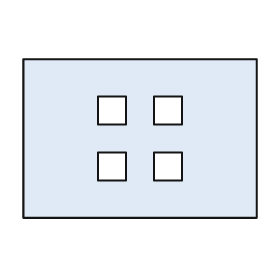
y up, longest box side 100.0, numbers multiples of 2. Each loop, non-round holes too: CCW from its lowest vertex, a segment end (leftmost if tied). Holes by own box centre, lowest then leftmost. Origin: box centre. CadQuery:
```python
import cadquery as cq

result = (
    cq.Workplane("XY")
    .moveTo(-50.0, -34.0)
    .lineTo(50.0, -34.0)
    .lineTo(50.0, 34.0)
    .lineTo(-50.0, 34.0)
    .close()
    .moveTo(-18.0, -18.0)
    .lineTo(-6.0, -18.0)
    .lineTo(-6.0, -6.0)
    .lineTo(-18.0, -6.0)
    .close()
    .moveTo(6.0, -18.0)
    .lineTo(18.0, -18.0)
    .lineTo(18.0, -6.0)
    .lineTo(6.0, -6.0)
    .close()
    .moveTo(-18.0, 6.0)
    .lineTo(-6.0, 6.0)
    .lineTo(-6.0, 18.0)
    .lineTo(-18.0, 18.0)
    .close()
    .moveTo(6.0, 6.0)
    .lineTo(18.0, 6.0)
    .lineTo(18.0, 18.0)
    .lineTo(6.0, 18.0)
    .close()
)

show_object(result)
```